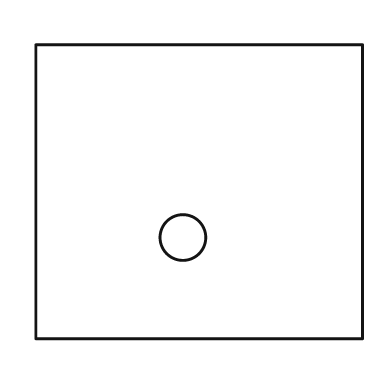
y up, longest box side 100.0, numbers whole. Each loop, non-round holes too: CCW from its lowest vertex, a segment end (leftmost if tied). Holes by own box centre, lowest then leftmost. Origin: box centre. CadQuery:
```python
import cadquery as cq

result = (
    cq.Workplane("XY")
    .moveTo(-50.0, -45.0)
    .lineTo(50.0, -45.0)
    .lineTo(50.0, 45.0)
    .lineTo(-50.0, 45.0)
    .close()
    .moveTo(-5.0, -14.0)
    .circle(7.0)
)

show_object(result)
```